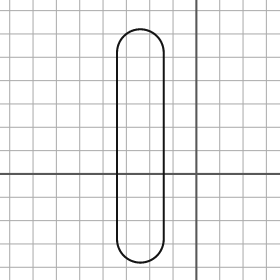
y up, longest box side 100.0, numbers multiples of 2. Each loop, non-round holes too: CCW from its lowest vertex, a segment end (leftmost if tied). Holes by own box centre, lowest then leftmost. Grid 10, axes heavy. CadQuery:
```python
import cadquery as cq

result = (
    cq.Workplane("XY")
    .moveTo(-34.0, -28.0)
    .threePointArc((-24.0, -38.0), (-14.0, -28.0))
    .lineTo(-14.0, 52.0)
    .threePointArc((-24.0, 62.0), (-34.0, 52.0))
    .close()
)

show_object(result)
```